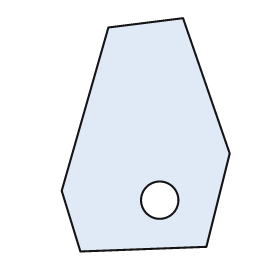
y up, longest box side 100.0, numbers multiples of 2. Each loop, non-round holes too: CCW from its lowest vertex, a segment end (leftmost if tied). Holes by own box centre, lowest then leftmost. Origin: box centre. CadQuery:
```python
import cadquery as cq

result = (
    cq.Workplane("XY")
    .moveTo(-28.0, -50.0)
    .lineTo(26.0, -48.0)
    .lineTo(36.0, -8.0)
    .lineTo(16.0, 50.0)
    .lineTo(-16.0, 46.0)
    .lineTo(-36.0, -24.0)
    .close()
    .moveTo(6.0, -28.0)
    .circle(8.0)
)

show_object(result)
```